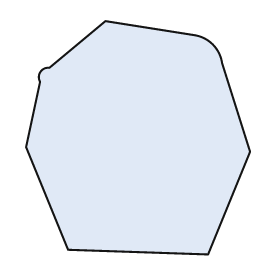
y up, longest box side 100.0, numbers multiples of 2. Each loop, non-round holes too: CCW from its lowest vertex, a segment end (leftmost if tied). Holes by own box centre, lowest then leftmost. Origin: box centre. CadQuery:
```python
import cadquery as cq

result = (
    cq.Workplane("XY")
    .moveTo(30.0, -50.0)
    .lineTo(48.0, -6.0)
    .lineTo(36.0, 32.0)
    .threePointArc((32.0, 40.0), (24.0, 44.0))
    .lineTo(-14.0, 50.0)
    .lineTo(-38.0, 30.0)
    .threePointArc((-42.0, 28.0), (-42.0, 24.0))
    .lineTo(-48.0, -4.0)
    .lineTo(-30.0, -48.0)
    .close()
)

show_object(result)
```